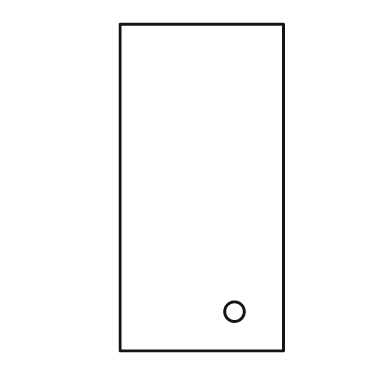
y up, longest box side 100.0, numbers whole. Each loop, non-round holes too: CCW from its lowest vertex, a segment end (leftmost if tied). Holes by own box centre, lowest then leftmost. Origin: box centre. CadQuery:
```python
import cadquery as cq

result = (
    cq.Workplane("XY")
    .moveTo(-25.0, -50.0)
    .lineTo(25.0, -50.0)
    .lineTo(25.0, 50.0)
    .lineTo(-25.0, 50.0)
    .close()
    .moveTo(10.0, -38.0)
    .circle(3.0)
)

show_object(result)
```